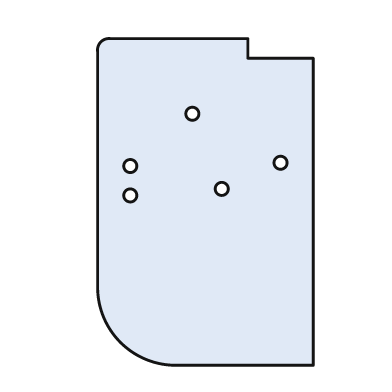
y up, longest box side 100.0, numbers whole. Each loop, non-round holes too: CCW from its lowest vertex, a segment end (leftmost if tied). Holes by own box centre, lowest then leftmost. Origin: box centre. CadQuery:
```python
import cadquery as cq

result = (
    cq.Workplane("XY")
    .moveTo(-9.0, -50.0)
    .lineTo(33.0, -50.0)
    .lineTo(33.0, 44.0)
    .lineTo(13.0, 44.0)
    .lineTo(13.0, 50.0)
    .lineTo(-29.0, 50.0)
    .threePointArc((-32.0, 49.0), (-33.0, 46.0))
    .lineTo(-33.0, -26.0)
    .threePointArc((-26.0, -43.0), (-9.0, -50.0))
    .close()
    .moveTo(-23.0, 2.0)
    .circle(2.0)
    .moveTo(5.0, 4.0)
    .circle(2.0)
    .moveTo(-23.0, 11.0)
    .circle(2.0)
    .moveTo(23.0, 12.0)
    .circle(2.0)
    .moveTo(-4.0, 27.0)
    .circle(2.0)
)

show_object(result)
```